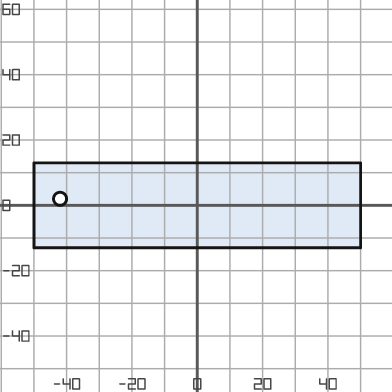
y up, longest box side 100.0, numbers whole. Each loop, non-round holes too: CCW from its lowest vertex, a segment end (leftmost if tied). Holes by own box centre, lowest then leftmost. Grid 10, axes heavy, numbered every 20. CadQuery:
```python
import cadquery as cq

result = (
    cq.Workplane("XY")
    .moveTo(-50.0, -13.0)
    .lineTo(50.0, -13.0)
    .lineTo(50.0, 13.0)
    .lineTo(-50.0, 13.0)
    .close()
    .moveTo(-42.0, 2.0)
    .circle(2.0)
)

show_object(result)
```